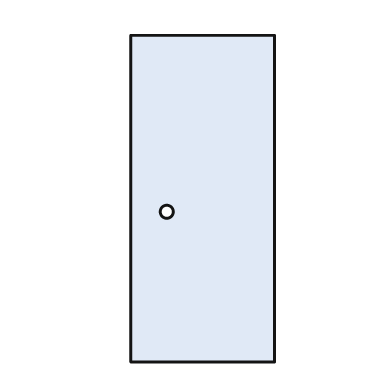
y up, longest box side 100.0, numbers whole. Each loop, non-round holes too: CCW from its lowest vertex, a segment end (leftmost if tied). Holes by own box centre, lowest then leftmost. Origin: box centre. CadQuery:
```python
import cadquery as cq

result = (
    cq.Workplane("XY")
    .moveTo(-22.0, -50.0)
    .lineTo(22.0, -50.0)
    .lineTo(22.0, 50.0)
    .lineTo(-22.0, 50.0)
    .close()
    .moveTo(-11.0, -4.0)
    .circle(2.0)
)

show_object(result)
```